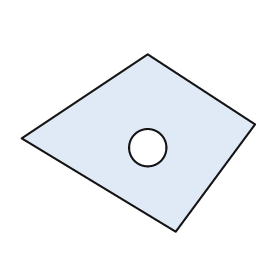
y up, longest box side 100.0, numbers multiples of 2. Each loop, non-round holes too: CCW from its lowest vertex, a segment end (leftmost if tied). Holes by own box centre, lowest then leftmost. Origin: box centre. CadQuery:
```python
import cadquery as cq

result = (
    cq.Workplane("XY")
    .moveTo(16.0, -38.0)
    .lineTo(50.0, 8.0)
    .lineTo(4.0, 38.0)
    .lineTo(-50.0, 2.0)
    .close()
    .moveTo(4.0, -2.0)
    .circle(8.0)
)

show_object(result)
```